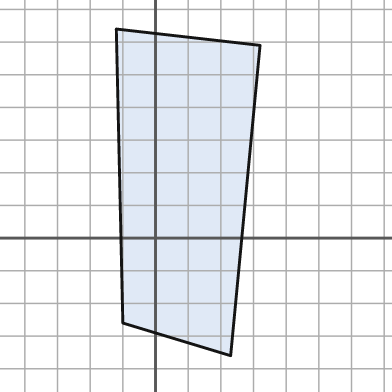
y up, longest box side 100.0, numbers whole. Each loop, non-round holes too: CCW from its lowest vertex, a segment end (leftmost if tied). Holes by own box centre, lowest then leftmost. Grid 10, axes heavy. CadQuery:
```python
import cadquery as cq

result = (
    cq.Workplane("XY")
    .moveTo(23.0, -36.0)
    .lineTo(32.0, 59.0)
    .lineTo(-12.0, 64.0)
    .lineTo(-10.0, -26.0)
    .close()
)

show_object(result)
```